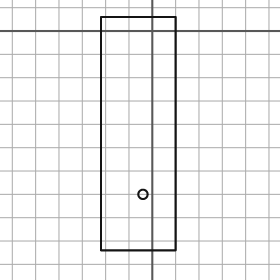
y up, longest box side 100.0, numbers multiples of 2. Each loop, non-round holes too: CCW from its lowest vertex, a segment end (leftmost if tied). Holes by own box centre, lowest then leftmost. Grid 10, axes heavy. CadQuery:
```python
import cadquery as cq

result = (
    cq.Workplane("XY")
    .moveTo(-22.0, -94.0)
    .lineTo(10.0, -94.0)
    .lineTo(10.0, 6.0)
    .lineTo(-22.0, 6.0)
    .close()
    .moveTo(-4.0, -70.0)
    .circle(2.0)
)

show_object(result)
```